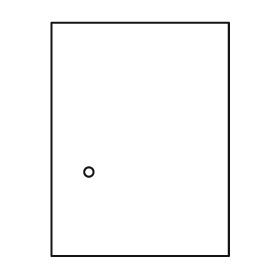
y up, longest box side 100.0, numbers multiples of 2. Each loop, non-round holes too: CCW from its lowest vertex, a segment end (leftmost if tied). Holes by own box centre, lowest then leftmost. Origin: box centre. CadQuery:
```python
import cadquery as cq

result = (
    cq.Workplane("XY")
    .moveTo(-38.0, -50.0)
    .lineTo(38.0, -50.0)
    .lineTo(38.0, 50.0)
    .lineTo(-38.0, 50.0)
    .close()
    .moveTo(-22.0, -14.0)
    .circle(2.0)
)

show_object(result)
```